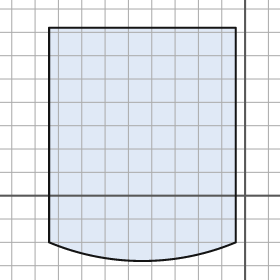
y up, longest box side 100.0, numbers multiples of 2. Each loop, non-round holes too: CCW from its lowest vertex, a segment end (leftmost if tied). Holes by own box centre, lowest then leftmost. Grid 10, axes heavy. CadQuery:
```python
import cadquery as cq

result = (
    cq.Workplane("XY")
    .moveTo(-84.0, -20.0)
    .threePointArc((-44.0, -28.0), (-4.0, -20.0))
    .lineTo(-4.0, 72.0)
    .lineTo(-84.0, 72.0)
    .close()
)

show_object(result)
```